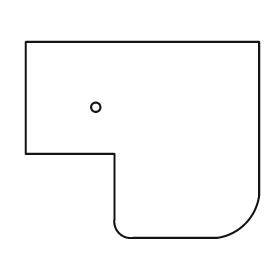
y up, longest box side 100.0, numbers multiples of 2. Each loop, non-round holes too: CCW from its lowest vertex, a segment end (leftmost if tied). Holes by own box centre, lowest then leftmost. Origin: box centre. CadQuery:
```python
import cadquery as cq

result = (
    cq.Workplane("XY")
    .moveTo(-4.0, -42.0)
    .lineTo(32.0, -42.0)
    .threePointArc((44.0, -36.0), (50.0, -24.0))
    .lineTo(50.0, 42.0)
    .lineTo(-50.0, 42.0)
    .lineTo(-50.0, -6.0)
    .lineTo(-12.0, -6.0)
    .lineTo(-12.0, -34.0)
    .threePointArc((-10.0, -40.0), (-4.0, -42.0))
    .close()
    .moveTo(-20.0, 14.0)
    .circle(2.0)
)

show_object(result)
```